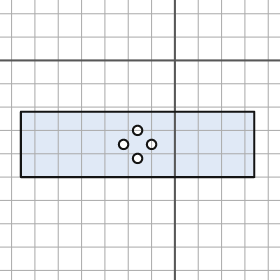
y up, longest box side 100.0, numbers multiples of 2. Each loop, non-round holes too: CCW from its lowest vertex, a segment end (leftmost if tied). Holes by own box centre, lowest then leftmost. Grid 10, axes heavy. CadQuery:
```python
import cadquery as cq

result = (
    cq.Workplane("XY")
    .moveTo(-66.0, -50.0)
    .lineTo(34.0, -50.0)
    .lineTo(34.0, -22.0)
    .lineTo(-66.0, -22.0)
    .close()
    .moveTo(-16.0, -42.0)
    .circle(2.0)
    .moveTo(-22.0, -36.0)
    .circle(2.0)
    .moveTo(-10.0, -36.0)
    .circle(2.0)
    .moveTo(-16.0, -30.0)
    .circle(2.0)
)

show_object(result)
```